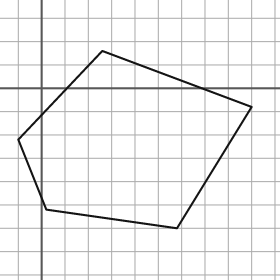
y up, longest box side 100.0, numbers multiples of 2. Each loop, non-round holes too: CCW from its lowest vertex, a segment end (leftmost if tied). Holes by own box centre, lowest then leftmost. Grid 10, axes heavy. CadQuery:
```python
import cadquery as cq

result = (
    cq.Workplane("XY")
    .moveTo(58.0, -60.0)
    .lineTo(90.0, -8.0)
    .lineTo(26.0, 16.0)
    .lineTo(-10.0, -22.0)
    .lineTo(2.0, -52.0)
    .close()
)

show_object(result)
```